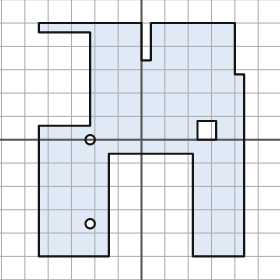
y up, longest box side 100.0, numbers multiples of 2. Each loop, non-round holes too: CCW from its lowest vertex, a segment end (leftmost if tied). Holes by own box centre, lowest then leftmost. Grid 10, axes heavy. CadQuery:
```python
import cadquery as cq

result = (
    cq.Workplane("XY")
    .moveTo(-44.0, -50.0)
    .lineTo(-14.0, -50.0)
    .lineTo(-14.0, -6.0)
    .lineTo(22.0, -6.0)
    .lineTo(22.0, -50.0)
    .lineTo(44.0, -50.0)
    .lineTo(44.0, 28.0)
    .lineTo(40.0, 28.0)
    .lineTo(40.0, 50.0)
    .lineTo(4.0, 50.0)
    .lineTo(4.0, 34.0)
    .lineTo(0.0, 34.0)
    .lineTo(0.0, 50.0)
    .lineTo(-44.0, 50.0)
    .lineTo(-44.0, 46.0)
    .lineTo(-22.0, 46.0)
    .lineTo(-22.0, 6.0)
    .lineTo(-44.0, 6.0)
    .close()
    .moveTo(-22.0, -36.0)
    .circle(2.0)
    .moveTo(-22.0, 0.0)
    .circle(2.0)
    .moveTo(24.0, 0.0)
    .lineTo(32.0, 0.0)
    .lineTo(32.0, 8.0)
    .lineTo(24.0, 8.0)
    .close()
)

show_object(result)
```